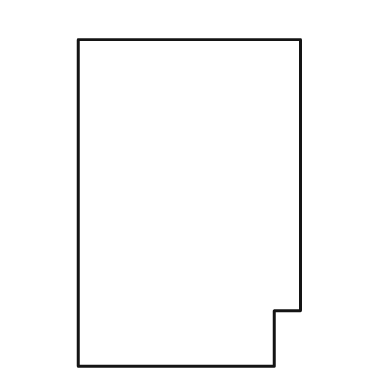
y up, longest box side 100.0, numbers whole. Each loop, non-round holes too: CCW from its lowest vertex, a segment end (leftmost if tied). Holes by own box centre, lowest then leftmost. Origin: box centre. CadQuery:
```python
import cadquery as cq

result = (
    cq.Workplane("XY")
    .moveTo(-34.0, -50.0)
    .lineTo(26.0, -50.0)
    .lineTo(26.0, -33.0)
    .lineTo(34.0, -33.0)
    .lineTo(34.0, 50.0)
    .lineTo(-34.0, 50.0)
    .close()
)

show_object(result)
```